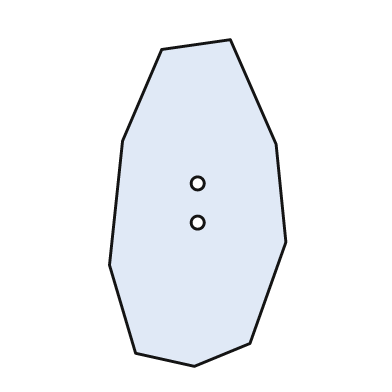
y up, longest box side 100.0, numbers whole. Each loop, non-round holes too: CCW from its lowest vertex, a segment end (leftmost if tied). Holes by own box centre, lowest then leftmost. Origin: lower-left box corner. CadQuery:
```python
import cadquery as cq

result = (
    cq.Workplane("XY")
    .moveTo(26.0, 0.0)
    .lineTo(43.0, 7.0)
    .lineTo(54.0, 38.0)
    .lineTo(51.0, 68.0)
    .lineTo(37.0, 100.0)
    .lineTo(16.0, 97.0)
    .lineTo(4.0, 69.0)
    .lineTo(0.0, 31.0)
    .lineTo(8.0, 4.0)
    .close()
    .moveTo(27.0, 44.0)
    .circle(2.0)
    .moveTo(27.0, 56.0)
    .circle(2.0)
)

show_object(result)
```